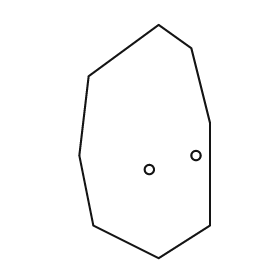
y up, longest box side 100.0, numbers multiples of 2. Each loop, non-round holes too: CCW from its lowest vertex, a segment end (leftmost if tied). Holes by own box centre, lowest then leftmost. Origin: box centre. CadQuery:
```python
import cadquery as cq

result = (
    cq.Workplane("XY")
    .moveTo(6.0, -50.0)
    .lineTo(28.0, -36.0)
    .lineTo(28.0, 8.0)
    .lineTo(20.0, 40.0)
    .lineTo(6.0, 50.0)
    .lineTo(-24.0, 28.0)
    .lineTo(-28.0, -6.0)
    .lineTo(-22.0, -36.0)
    .close()
    .moveTo(2.0, -12.0)
    .circle(2.0)
    .moveTo(22.0, -6.0)
    .circle(2.0)
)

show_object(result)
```